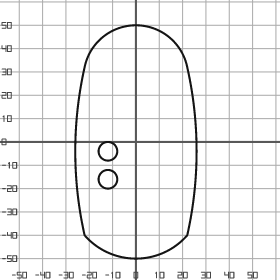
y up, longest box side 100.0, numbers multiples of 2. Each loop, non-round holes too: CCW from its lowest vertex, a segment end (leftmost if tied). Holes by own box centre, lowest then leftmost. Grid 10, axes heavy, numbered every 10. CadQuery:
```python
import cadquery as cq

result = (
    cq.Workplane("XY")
    .moveTo(-22.0, -40.0)
    .threePointArc((0.0, -50.0), (22.0, -40.0))
    .threePointArc((26.0, -4.0), (22.0, 32.0))
    .threePointArc((0.0, 50.0), (-22.0, 32.0))
    .threePointArc((-26.0, -4.0), (-22.0, -40.0))
    .close()
    .moveTo(-12.0, -16.0)
    .circle(4.0)
    .moveTo(-12.0, -4.0)
    .circle(4.0)
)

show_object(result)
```